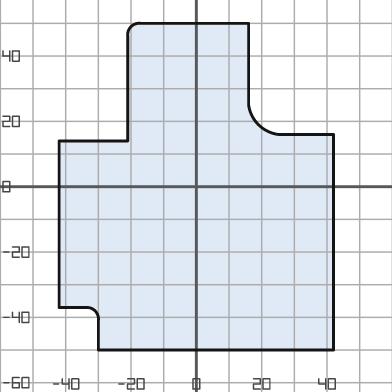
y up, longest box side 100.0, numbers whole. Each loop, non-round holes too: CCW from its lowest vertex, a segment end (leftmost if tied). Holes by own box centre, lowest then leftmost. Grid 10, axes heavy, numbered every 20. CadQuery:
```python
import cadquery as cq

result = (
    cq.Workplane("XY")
    .moveTo(-30.0, -50.0)
    .lineTo(42.0, -50.0)
    .lineTo(42.0, 16.0)
    .lineTo(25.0, 16.0)
    .threePointArc((19.0, 19.0), (16.0, 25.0))
    .lineTo(16.0, 50.0)
    .lineTo(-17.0, 50.0)
    .threePointArc((-20.0, 49.0), (-21.0, 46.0))
    .lineTo(-21.0, 14.0)
    .lineTo(-42.0, 14.0)
    .lineTo(-42.0, -37.0)
    .lineTo(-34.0, -37.0)
    .threePointArc((-31.0, -38.0), (-30.0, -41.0))
    .close()
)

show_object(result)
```